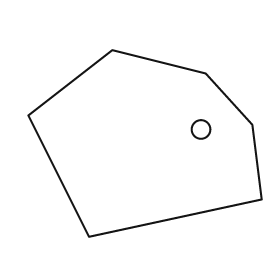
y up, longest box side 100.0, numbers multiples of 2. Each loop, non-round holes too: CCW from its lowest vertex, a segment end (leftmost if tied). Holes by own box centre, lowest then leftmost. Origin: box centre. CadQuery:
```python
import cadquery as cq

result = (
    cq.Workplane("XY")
    .moveTo(-24.0, -40.0)
    .lineTo(50.0, -24.0)
    .lineTo(46.0, 8.0)
    .lineTo(26.0, 30.0)
    .lineTo(-14.0, 40.0)
    .lineTo(-50.0, 12.0)
    .close()
    .moveTo(24.0, 6.0)
    .circle(4.0)
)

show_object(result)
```